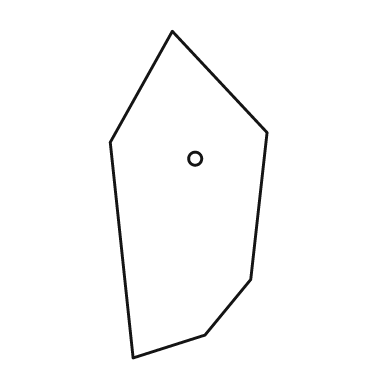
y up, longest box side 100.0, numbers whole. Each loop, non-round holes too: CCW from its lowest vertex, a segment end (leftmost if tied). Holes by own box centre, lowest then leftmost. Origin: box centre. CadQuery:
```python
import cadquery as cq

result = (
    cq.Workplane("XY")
    .moveTo(-17.0, -50.0)
    .lineTo(5.0, -43.0)
    .lineTo(19.0, -26.0)
    .lineTo(24.0, 19.0)
    .lineTo(-5.0, 50.0)
    .lineTo(-24.0, 16.0)
    .close()
    .moveTo(2.0, 11.0)
    .circle(2.0)
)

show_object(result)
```